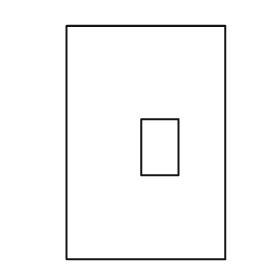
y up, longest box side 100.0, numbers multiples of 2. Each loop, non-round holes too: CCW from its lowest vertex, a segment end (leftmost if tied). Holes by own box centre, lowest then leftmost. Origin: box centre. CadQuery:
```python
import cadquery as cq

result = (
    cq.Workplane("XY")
    .moveTo(-34.0, -50.0)
    .lineTo(34.0, -50.0)
    .lineTo(34.0, 50.0)
    .lineTo(-34.0, 50.0)
    .close()
    .moveTo(-2.0, -14.0)
    .lineTo(14.0, -14.0)
    .lineTo(14.0, 10.0)
    .lineTo(-2.0, 10.0)
    .close()
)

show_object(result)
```